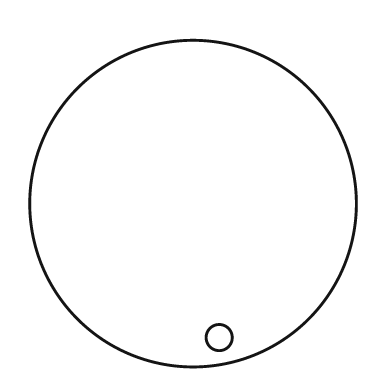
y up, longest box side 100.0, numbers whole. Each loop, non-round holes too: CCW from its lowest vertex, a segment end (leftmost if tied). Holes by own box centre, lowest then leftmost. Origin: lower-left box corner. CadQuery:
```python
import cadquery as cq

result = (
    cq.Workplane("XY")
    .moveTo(50.0, 50.0)
    .circle(50.0)
    .moveTo(58.0, 9.0)
    .circle(4.0)
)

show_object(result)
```